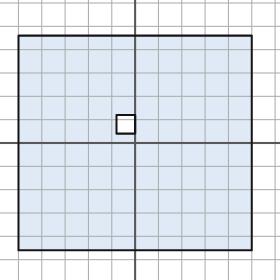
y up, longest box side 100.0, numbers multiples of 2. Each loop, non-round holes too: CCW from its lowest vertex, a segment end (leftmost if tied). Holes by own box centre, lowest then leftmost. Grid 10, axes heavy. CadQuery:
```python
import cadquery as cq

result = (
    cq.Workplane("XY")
    .moveTo(-50.0, -46.0)
    .lineTo(50.0, -46.0)
    .lineTo(50.0, 46.0)
    .lineTo(-50.0, 46.0)
    .close()
    .moveTo(-8.0, 4.0)
    .lineTo(0.0, 4.0)
    .lineTo(0.0, 12.0)
    .lineTo(-8.0, 12.0)
    .close()
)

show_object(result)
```